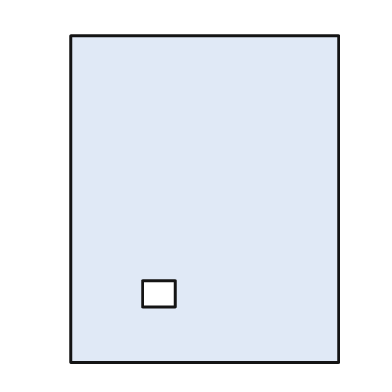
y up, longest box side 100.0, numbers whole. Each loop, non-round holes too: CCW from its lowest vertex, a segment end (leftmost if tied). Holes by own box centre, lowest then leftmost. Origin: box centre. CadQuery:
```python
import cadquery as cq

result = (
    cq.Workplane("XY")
    .moveTo(-41.0, -50.0)
    .lineTo(41.0, -50.0)
    .lineTo(41.0, 50.0)
    .lineTo(-41.0, 50.0)
    .close()
    .moveTo(-19.0, -33.0)
    .lineTo(-9.0, -33.0)
    .lineTo(-9.0, -25.0)
    .lineTo(-19.0, -25.0)
    .close()
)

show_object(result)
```